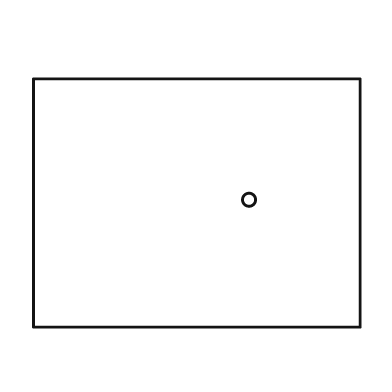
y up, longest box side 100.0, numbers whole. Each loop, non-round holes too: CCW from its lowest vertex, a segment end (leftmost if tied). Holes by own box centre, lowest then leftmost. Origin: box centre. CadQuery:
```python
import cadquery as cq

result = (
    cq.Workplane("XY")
    .moveTo(-50.0, -38.0)
    .lineTo(50.0, -38.0)
    .lineTo(50.0, 38.0)
    .lineTo(-50.0, 38.0)
    .close()
    .moveTo(16.0, 1.0)
    .circle(2.0)
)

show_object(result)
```